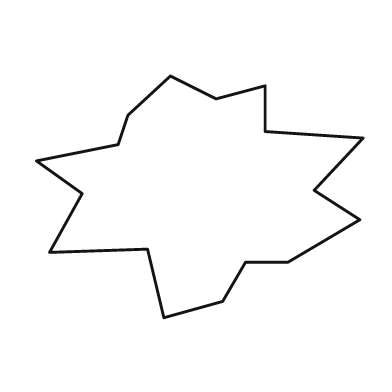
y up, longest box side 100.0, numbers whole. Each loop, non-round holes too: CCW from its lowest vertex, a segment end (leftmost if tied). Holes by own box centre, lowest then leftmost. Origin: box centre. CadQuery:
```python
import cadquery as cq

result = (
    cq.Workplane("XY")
    .moveTo(-11.0, -37.0)
    .lineTo(7.0, -32.0)
    .lineTo(14.0, -20.0)
    .lineTo(27.0, -20.0)
    .lineTo(49.0, -7.0)
    .lineTo(35.0, 2.0)
    .lineTo(50.0, 18.0)
    .lineTo(20.0, 20.0)
    .lineTo(20.0, 34.0)
    .lineTo(5.0, 30.0)
    .lineTo(-9.0, 37.0)
    .lineTo(-22.0, 25.0)
    .lineTo(-25.0, 16.0)
    .lineTo(-50.0, 11.0)
    .lineTo(-36.0, 1.0)
    .lineTo(-46.0, -17.0)
    .lineTo(-16.0, -16.0)
    .close()
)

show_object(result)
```